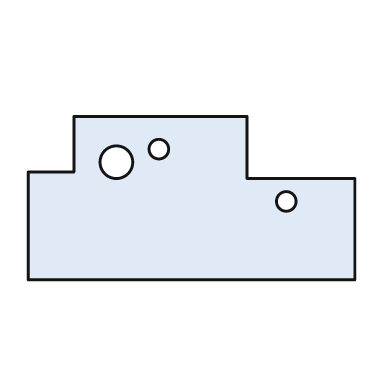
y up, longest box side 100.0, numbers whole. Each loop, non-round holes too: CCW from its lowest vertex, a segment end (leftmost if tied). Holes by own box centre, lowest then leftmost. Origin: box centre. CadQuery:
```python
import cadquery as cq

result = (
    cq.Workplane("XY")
    .moveTo(-50.0, -25.0)
    .lineTo(50.0, -25.0)
    .lineTo(50.0, 6.0)
    .lineTo(17.0, 6.0)
    .lineTo(17.0, 25.0)
    .lineTo(-36.0, 25.0)
    .lineTo(-36.0, 8.0)
    .lineTo(-50.0, 8.0)
    .close()
    .moveTo(29.0, -1.0)
    .circle(3.0)
    .moveTo(-23.0, 11.0)
    .circle(5.0)
    .moveTo(-10.0, 15.0)
    .circle(3.0)
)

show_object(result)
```